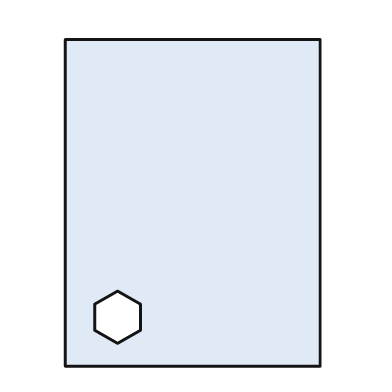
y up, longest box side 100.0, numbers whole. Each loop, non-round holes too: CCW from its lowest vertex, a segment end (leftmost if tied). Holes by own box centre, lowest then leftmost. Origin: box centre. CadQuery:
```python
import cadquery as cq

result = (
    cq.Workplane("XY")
    .moveTo(-39.0, -50.0)
    .lineTo(39.0, -50.0)
    .lineTo(39.0, 50.0)
    .lineTo(-39.0, 50.0)
    .close()
    .moveTo(-23.0, -43.0)
    .lineTo(-16.0, -39.0)
    .lineTo(-16.0, -31.0)
    .lineTo(-23.0, -27.0)
    .lineTo(-30.0, -31.0)
    .lineTo(-30.0, -39.0)
    .close()
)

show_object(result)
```